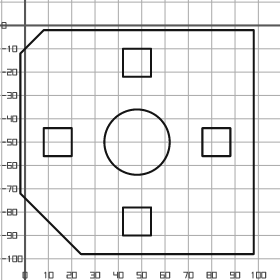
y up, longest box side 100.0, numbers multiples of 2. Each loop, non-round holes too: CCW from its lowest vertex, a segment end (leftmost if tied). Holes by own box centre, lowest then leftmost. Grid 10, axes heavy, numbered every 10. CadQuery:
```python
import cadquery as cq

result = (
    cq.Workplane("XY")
    .moveTo(24.0, -98.0)
    .lineTo(98.0, -98.0)
    .lineTo(98.0, -2.0)
    .lineTo(8.0, -2.0)
    .lineTo(-2.0, -12.0)
    .lineTo(-2.0, -72.0)
    .close()
    .moveTo(42.0, -90.0)
    .lineTo(54.0, -90.0)
    .lineTo(54.0, -78.0)
    .lineTo(42.0, -78.0)
    .close()
    .moveTo(8.0, -56.0)
    .lineTo(20.0, -56.0)
    .lineTo(20.0, -44.0)
    .lineTo(8.0, -44.0)
    .close()
    .moveTo(48.0, -50.0)
    .circle(14.0)
    .moveTo(76.0, -56.0)
    .lineTo(88.0, -56.0)
    .lineTo(88.0, -44.0)
    .lineTo(76.0, -44.0)
    .close()
    .moveTo(42.0, -22.0)
    .lineTo(54.0, -22.0)
    .lineTo(54.0, -10.0)
    .lineTo(42.0, -10.0)
    .close()
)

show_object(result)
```